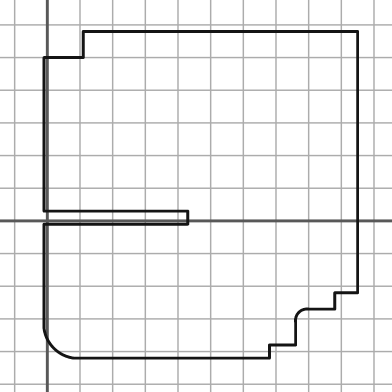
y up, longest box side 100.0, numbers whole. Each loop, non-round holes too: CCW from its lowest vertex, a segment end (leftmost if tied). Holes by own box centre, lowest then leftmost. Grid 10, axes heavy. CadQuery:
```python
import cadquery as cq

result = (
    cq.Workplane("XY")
    .moveTo(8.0, -42.0)
    .lineTo(68.0, -42.0)
    .lineTo(68.0, -38.0)
    .lineTo(76.0, -38.0)
    .lineTo(76.0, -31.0)
    .threePointArc((77.0, -28.0), (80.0, -27.0))
    .lineTo(88.0, -27.0)
    .lineTo(88.0, -22.0)
    .lineTo(95.0, -22.0)
    .lineTo(95.0, 58.0)
    .lineTo(11.0, 58.0)
    .lineTo(11.0, 50.0)
    .lineTo(-1.0, 50.0)
    .lineTo(-1.0, 3.0)
    .lineTo(43.0, 3.0)
    .lineTo(43.0, -1.0)
    .lineTo(-1.0, -1.0)
    .lineTo(-1.0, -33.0)
    .threePointArc((2.0, -39.0), (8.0, -42.0))
    .close()
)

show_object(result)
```